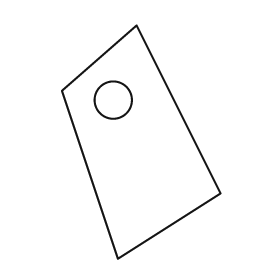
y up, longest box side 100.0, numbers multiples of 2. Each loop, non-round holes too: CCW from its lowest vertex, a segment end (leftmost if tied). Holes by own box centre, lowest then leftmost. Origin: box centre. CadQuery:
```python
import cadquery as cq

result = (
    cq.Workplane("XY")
    .moveTo(-10.0, -50.0)
    .lineTo(34.0, -22.0)
    .lineTo(-2.0, 50.0)
    .lineTo(-34.0, 22.0)
    .close()
    .moveTo(-12.0, 18.0)
    .circle(8.0)
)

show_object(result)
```